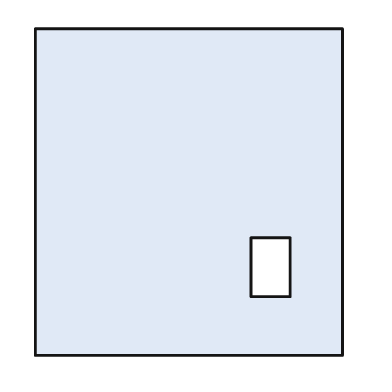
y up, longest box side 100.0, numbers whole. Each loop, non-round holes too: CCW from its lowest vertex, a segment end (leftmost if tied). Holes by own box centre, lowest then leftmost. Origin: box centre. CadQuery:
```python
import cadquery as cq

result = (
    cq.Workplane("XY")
    .moveTo(-47.0, -50.0)
    .lineTo(47.0, -50.0)
    .lineTo(47.0, 50.0)
    .lineTo(-47.0, 50.0)
    .close()
    .moveTo(19.0, -32.0)
    .lineTo(31.0, -32.0)
    .lineTo(31.0, -14.0)
    .lineTo(19.0, -14.0)
    .close()
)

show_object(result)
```